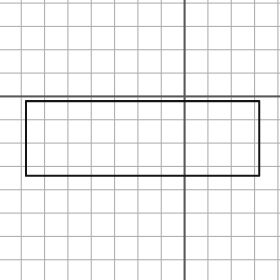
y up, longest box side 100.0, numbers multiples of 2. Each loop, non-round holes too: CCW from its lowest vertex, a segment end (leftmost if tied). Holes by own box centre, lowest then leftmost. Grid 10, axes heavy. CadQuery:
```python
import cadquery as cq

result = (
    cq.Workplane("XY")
    .moveTo(-68.0, -34.0)
    .lineTo(32.0, -34.0)
    .lineTo(32.0, -2.0)
    .lineTo(-68.0, -2.0)
    .close()
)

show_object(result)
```